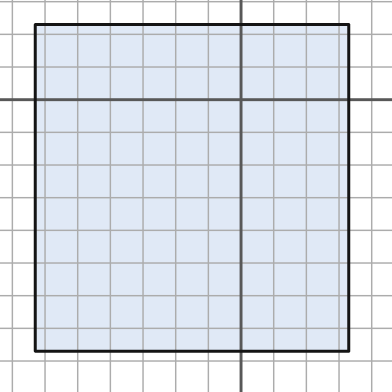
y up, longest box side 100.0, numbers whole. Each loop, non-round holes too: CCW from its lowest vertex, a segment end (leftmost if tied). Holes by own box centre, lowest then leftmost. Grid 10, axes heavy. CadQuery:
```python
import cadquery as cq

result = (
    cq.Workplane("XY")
    .moveTo(-63.0, -77.0)
    .lineTo(33.0, -77.0)
    .lineTo(33.0, 23.0)
    .lineTo(-63.0, 23.0)
    .close()
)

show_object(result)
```